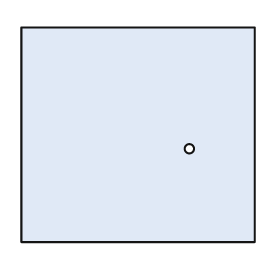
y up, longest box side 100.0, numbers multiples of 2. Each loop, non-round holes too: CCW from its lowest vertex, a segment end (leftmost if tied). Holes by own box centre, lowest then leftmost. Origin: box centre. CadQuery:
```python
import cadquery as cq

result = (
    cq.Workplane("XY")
    .moveTo(-50.0, -46.0)
    .lineTo(50.0, -46.0)
    .lineTo(50.0, 46.0)
    .lineTo(-50.0, 46.0)
    .close()
    .moveTo(22.0, -6.0)
    .circle(2.0)
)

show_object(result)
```